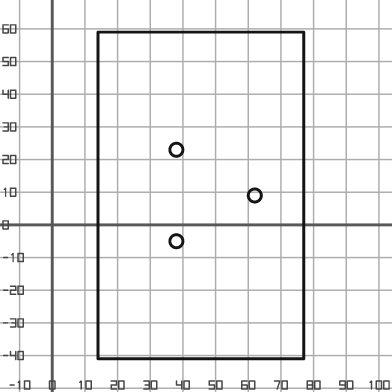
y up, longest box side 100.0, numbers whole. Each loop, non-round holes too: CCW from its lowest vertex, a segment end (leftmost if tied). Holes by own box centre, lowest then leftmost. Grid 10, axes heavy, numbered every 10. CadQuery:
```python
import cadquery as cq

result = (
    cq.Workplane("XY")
    .moveTo(14.0, -41.0)
    .lineTo(77.0, -41.0)
    .lineTo(77.0, 59.0)
    .lineTo(14.0, 59.0)
    .close()
    .moveTo(38.0, -5.0)
    .circle(2.0)
    .moveTo(62.0, 9.0)
    .circle(2.0)
    .moveTo(38.0, 23.0)
    .circle(2.0)
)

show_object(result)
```